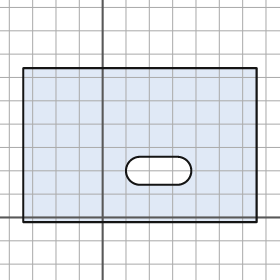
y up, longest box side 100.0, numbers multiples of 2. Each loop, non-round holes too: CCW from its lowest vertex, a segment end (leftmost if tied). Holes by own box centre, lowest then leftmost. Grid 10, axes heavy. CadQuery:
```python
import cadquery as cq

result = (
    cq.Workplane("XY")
    .moveTo(-34.0, -2.0)
    .lineTo(66.0, -2.0)
    .lineTo(66.0, 64.0)
    .lineTo(-34.0, 64.0)
    .close()
    .moveTo(16.0, 14.0)
    .lineTo(32.0, 14.0)
    .threePointArc((38.0, 20.0), (32.0, 26.0))
    .lineTo(16.0, 26.0)
    .threePointArc((10.0, 20.0), (16.0, 14.0))
    .close()
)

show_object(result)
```